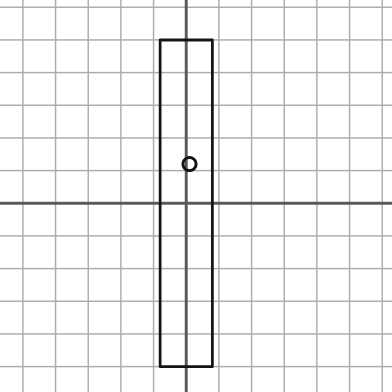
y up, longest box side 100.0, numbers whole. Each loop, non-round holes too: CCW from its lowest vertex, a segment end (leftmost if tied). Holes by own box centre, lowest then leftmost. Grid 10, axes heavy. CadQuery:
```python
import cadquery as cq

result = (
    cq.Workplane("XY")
    .moveTo(-8.0, -50.0)
    .lineTo(8.0, -50.0)
    .lineTo(8.0, 50.0)
    .lineTo(-8.0, 50.0)
    .close()
    .moveTo(1.0, 12.0)
    .circle(2.0)
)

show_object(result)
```